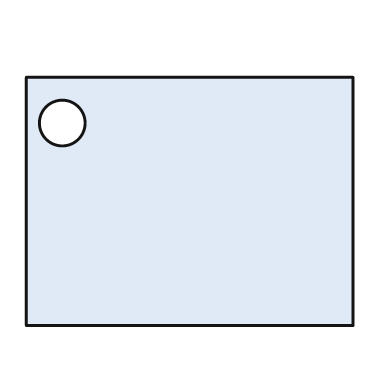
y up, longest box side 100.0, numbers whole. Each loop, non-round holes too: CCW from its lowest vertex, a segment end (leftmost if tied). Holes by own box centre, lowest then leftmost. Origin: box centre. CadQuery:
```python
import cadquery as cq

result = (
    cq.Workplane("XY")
    .moveTo(-50.0, -38.0)
    .lineTo(50.0, -38.0)
    .lineTo(50.0, 38.0)
    .lineTo(-50.0, 38.0)
    .close()
    .moveTo(-39.0, 24.0)
    .circle(7.0)
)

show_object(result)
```